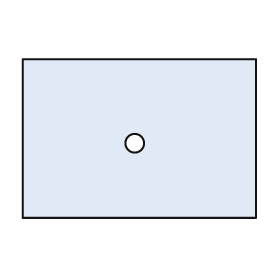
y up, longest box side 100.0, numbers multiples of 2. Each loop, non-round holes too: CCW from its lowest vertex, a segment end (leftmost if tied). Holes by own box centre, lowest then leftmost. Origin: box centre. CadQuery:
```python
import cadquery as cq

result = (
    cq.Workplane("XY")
    .moveTo(-50.0, -34.0)
    .lineTo(50.0, -34.0)
    .lineTo(50.0, 34.0)
    .lineTo(-50.0, 34.0)
    .close()
    .moveTo(-2.0, -2.0)
    .circle(4.0)
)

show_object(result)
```